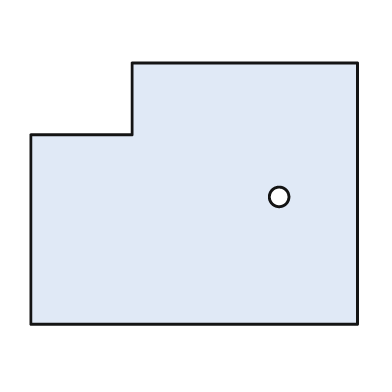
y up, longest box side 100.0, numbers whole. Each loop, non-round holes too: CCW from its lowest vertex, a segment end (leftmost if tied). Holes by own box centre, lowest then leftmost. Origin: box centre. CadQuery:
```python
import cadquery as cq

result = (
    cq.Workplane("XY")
    .moveTo(-50.0, -40.0)
    .lineTo(50.0, -40.0)
    .lineTo(50.0, 40.0)
    .lineTo(-19.0, 40.0)
    .lineTo(-19.0, 18.0)
    .lineTo(-50.0, 18.0)
    .close()
    .moveTo(26.0, -1.0)
    .circle(3.0)
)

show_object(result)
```